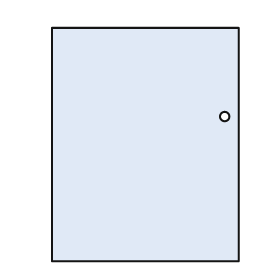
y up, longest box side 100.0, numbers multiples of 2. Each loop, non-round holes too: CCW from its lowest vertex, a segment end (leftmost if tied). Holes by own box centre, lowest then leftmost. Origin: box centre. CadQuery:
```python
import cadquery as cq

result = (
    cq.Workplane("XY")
    .moveTo(-40.0, -50.0)
    .lineTo(40.0, -50.0)
    .lineTo(40.0, 50.0)
    .lineTo(-40.0, 50.0)
    .close()
    .moveTo(34.0, 12.0)
    .circle(2.0)
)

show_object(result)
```